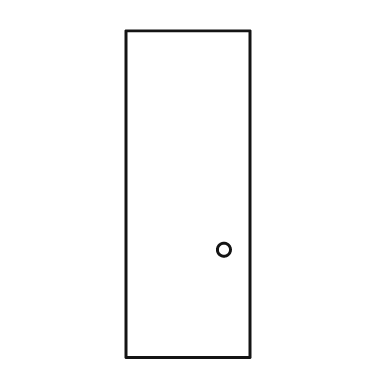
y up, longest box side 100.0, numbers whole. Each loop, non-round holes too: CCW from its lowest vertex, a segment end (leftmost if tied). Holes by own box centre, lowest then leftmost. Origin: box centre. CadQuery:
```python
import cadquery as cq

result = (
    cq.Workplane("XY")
    .moveTo(-19.0, -50.0)
    .lineTo(19.0, -50.0)
    .lineTo(19.0, 50.0)
    .lineTo(-19.0, 50.0)
    .close()
    .moveTo(11.0, -17.0)
    .circle(2.0)
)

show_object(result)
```